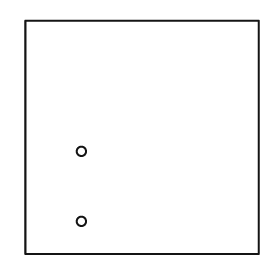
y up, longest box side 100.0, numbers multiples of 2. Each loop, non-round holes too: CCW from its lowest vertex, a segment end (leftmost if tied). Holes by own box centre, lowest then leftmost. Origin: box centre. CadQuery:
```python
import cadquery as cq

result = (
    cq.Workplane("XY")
    .moveTo(-50.0, -50.0)
    .lineTo(50.0, -50.0)
    .lineTo(50.0, 50.0)
    .lineTo(-50.0, 50.0)
    .close()
    .moveTo(-26.0, -36.0)
    .circle(2.0)
    .moveTo(-26.0, -6.0)
    .circle(2.0)
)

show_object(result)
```